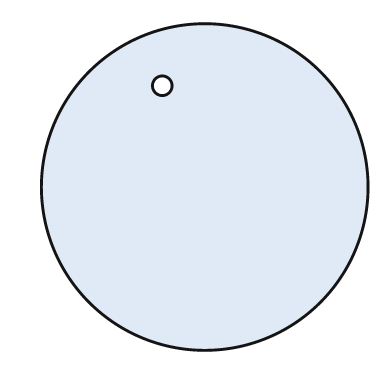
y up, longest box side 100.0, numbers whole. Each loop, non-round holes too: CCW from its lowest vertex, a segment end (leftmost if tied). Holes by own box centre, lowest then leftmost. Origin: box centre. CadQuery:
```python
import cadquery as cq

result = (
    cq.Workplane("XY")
    .moveTo(0.0, 0.0)
    .circle(50.0)
    .moveTo(-13.0, 31.0)
    .circle(3.0)
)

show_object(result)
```